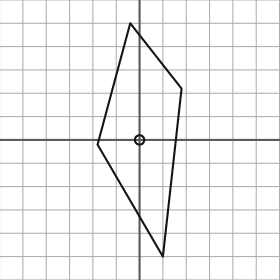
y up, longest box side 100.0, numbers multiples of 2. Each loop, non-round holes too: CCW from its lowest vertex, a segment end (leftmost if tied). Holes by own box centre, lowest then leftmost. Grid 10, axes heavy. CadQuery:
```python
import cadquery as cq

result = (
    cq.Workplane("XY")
    .moveTo(10.0, -50.0)
    .lineTo(18.0, 22.0)
    .lineTo(-4.0, 50.0)
    .lineTo(-18.0, -2.0)
    .close()
    .moveTo(0.0, 0.0)
    .circle(2.0)
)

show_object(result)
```